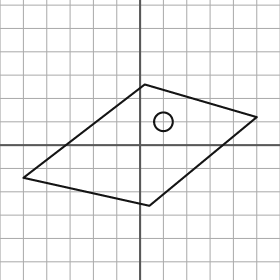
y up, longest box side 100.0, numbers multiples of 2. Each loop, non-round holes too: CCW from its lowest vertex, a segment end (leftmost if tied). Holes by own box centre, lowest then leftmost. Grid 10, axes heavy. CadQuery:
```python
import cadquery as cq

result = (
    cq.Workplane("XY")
    .moveTo(4.0, -26.0)
    .lineTo(50.0, 12.0)
    .lineTo(2.0, 26.0)
    .lineTo(-50.0, -14.0)
    .close()
    .moveTo(10.0, 10.0)
    .circle(4.0)
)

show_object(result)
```